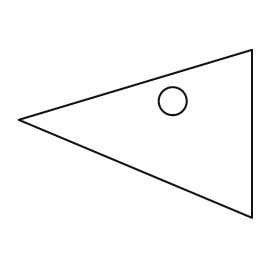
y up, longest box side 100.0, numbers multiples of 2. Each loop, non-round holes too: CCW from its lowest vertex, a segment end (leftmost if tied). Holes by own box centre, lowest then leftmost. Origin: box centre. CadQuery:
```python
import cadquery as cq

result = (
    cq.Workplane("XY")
    .moveTo(50.0, -36.0)
    .lineTo(50.0, 36.0)
    .lineTo(-50.0, 6.0)
    .close()
    .moveTo(16.0, 14.0)
    .circle(6.0)
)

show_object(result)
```